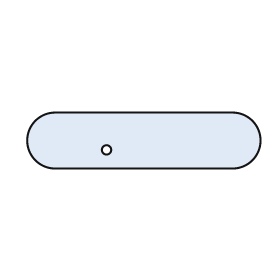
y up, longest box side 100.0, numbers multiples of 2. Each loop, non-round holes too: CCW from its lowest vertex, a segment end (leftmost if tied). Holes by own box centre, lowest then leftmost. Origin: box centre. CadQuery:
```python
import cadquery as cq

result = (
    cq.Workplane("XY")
    .moveTo(-38.0, -12.0)
    .lineTo(38.0, -12.0)
    .threePointArc((50.0, 0.0), (38.0, 12.0))
    .lineTo(-38.0, 12.0)
    .threePointArc((-50.0, 0.0), (-38.0, -12.0))
    .close()
    .moveTo(-16.0, -4.0)
    .circle(2.0)
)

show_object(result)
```